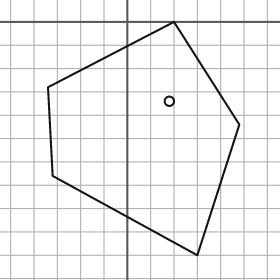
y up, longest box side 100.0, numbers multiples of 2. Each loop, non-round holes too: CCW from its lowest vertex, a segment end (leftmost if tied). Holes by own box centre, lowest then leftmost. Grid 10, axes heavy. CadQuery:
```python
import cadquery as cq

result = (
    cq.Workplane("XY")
    .moveTo(30.0, -100.0)
    .lineTo(48.0, -44.0)
    .lineTo(20.0, 0.0)
    .lineTo(-34.0, -28.0)
    .lineTo(-32.0, -66.0)
    .close()
    .moveTo(18.0, -34.0)
    .circle(2.0)
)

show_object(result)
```